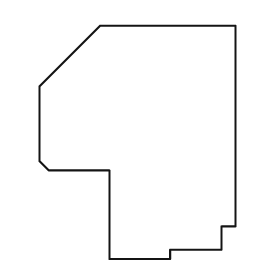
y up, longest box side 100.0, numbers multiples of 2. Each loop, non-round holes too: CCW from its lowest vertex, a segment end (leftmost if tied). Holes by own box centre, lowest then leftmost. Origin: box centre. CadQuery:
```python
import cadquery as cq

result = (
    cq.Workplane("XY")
    .moveTo(-12.0, -50.0)
    .lineTo(14.0, -50.0)
    .lineTo(14.0, -46.0)
    .lineTo(36.0, -46.0)
    .lineTo(36.0, -36.0)
    .lineTo(42.0, -36.0)
    .lineTo(42.0, 50.0)
    .lineTo(-16.0, 50.0)
    .lineTo(-42.0, 24.0)
    .lineTo(-42.0, -8.0)
    .lineTo(-38.0, -12.0)
    .lineTo(-12.0, -12.0)
    .close()
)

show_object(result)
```